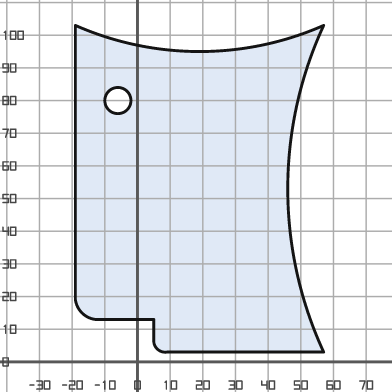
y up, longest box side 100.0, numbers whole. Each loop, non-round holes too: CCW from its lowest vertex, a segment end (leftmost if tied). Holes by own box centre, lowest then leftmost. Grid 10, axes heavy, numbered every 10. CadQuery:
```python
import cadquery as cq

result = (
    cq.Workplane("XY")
    .moveTo(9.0, 3.0)
    .lineTo(57.0, 3.0)
    .threePointArc((46.0, 53.0), (57.0, 103.0))
    .threePointArc((19.0, 95.0), (-19.0, 103.0))
    .lineTo(-19.0, 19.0)
    .threePointArc((-17.0, 15.0), (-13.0, 13.0))
    .lineTo(5.0, 13.0)
    .lineTo(5.0, 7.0)
    .threePointArc((6.0, 4.0), (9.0, 3.0))
    .close()
    .moveTo(-6.0, 80.0)
    .circle(4.0)
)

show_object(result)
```